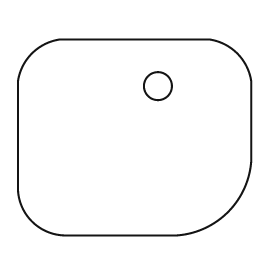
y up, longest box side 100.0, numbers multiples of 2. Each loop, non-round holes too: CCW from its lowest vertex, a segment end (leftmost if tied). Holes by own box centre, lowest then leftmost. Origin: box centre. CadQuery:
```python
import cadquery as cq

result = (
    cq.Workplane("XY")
    .moveTo(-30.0, -42.0)
    .lineTo(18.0, -42.0)
    .threePointArc((40.0, -32.0), (50.0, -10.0))
    .lineTo(50.0, 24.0)
    .threePointArc((44.0, 36.0), (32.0, 42.0))
    .lineTo(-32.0, 42.0)
    .threePointArc((-44.0, 36.0), (-50.0, 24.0))
    .lineTo(-50.0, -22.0)
    .threePointArc((-44.0, -36.0), (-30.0, -42.0))
    .close()
    .moveTo(10.0, 22.0)
    .circle(6.0)
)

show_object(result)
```